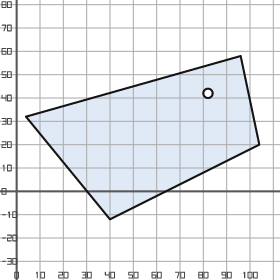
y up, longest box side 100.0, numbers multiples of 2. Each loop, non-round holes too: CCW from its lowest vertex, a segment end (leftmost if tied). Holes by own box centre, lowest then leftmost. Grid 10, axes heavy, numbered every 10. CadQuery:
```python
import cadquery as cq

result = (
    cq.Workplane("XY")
    .moveTo(40.0, -12.0)
    .lineTo(104.0, 20.0)
    .lineTo(96.0, 58.0)
    .lineTo(4.0, 32.0)
    .close()
    .moveTo(82.0, 42.0)
    .circle(2.0)
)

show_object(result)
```